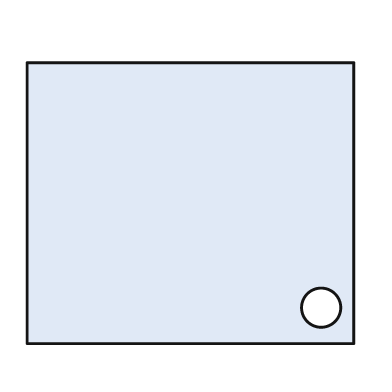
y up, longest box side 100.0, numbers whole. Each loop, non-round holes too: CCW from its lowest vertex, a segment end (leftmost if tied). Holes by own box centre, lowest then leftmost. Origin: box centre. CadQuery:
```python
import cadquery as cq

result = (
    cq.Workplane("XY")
    .moveTo(-50.0, -43.0)
    .lineTo(50.0, -43.0)
    .lineTo(50.0, 43.0)
    .lineTo(-50.0, 43.0)
    .close()
    .moveTo(40.0, -32.0)
    .circle(6.0)
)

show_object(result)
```